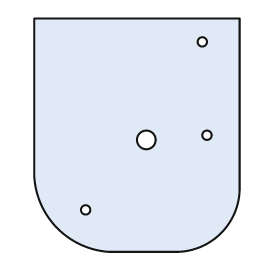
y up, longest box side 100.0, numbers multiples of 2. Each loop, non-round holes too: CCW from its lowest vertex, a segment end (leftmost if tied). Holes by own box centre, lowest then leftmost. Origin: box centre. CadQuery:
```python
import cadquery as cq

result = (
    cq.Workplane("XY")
    .moveTo(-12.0, -50.0)
    .lineTo(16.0, -50.0)
    .threePointArc((36.0, -42.0), (44.0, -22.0))
    .lineTo(44.0, 50.0)
    .lineTo(-44.0, 50.0)
    .lineTo(-44.0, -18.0)
    .threePointArc((-34.0, -40.0), (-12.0, -50.0))
    .close()
    .moveTo(-22.0, -32.0)
    .circle(2.0)
    .moveTo(4.0, -2.0)
    .circle(4.0)
    .moveTo(30.0, 0.0)
    .circle(2.0)
    .moveTo(28.0, 40.0)
    .circle(2.0)
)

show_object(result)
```